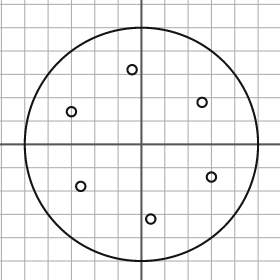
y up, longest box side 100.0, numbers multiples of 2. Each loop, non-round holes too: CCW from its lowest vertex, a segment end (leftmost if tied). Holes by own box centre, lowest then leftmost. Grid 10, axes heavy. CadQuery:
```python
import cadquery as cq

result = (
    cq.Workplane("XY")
    .moveTo(0.0, 0.0)
    .circle(50.0)
    .moveTo(4.0, -32.0)
    .circle(2.0)
    .moveTo(-26.0, -18.0)
    .circle(2.0)
    .moveTo(30.0, -14.0)
    .circle(2.0)
    .moveTo(-30.0, 14.0)
    .circle(2.0)
    .moveTo(26.0, 18.0)
    .circle(2.0)
    .moveTo(-4.0, 32.0)
    .circle(2.0)
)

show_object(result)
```